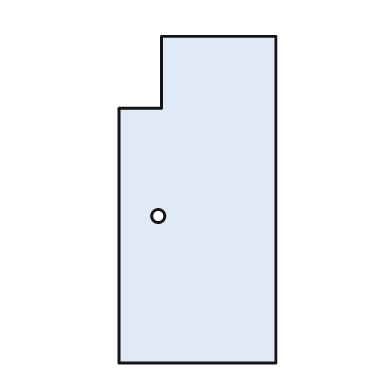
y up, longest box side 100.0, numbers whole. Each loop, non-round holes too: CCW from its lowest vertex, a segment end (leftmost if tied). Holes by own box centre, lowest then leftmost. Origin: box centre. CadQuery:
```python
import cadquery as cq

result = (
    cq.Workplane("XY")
    .moveTo(-24.0, -50.0)
    .lineTo(24.0, -50.0)
    .lineTo(24.0, 50.0)
    .lineTo(-11.0, 50.0)
    .lineTo(-11.0, 28.0)
    .lineTo(-24.0, 28.0)
    .close()
    .moveTo(-12.0, -5.0)
    .circle(2.0)
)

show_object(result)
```